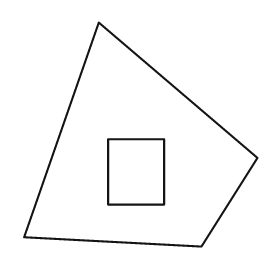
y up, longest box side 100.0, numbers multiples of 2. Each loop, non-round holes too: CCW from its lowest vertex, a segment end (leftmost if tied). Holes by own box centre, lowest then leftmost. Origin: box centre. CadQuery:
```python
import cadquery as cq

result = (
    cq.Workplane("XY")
    .moveTo(26.0, -48.0)
    .lineTo(50.0, -10.0)
    .lineTo(-18.0, 48.0)
    .lineTo(-50.0, -44.0)
    .close()
    .moveTo(-14.0, -30.0)
    .lineTo(10.0, -30.0)
    .lineTo(10.0, -2.0)
    .lineTo(-14.0, -2.0)
    .close()
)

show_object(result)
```